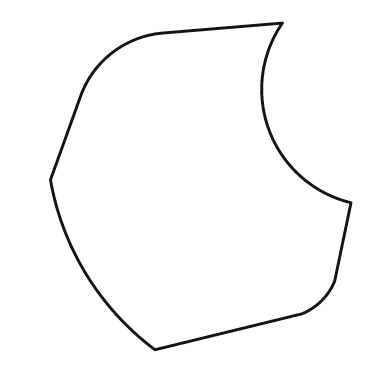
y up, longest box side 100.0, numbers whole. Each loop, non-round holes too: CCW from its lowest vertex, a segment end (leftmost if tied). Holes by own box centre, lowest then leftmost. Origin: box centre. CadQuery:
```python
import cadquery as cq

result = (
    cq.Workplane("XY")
    .moveTo(-14.0, -50.0)
    .lineTo(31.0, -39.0)
    .threePointArc((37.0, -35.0), (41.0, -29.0))
    .lineTo(46.0, -5.0)
    .threePointArc((21.0, 17.0), (25.0, 50.0))
    .lineTo(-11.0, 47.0)
    .threePointArc((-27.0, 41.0), (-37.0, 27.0))
    .lineTo(-46.0, 2.0)
    .threePointArc((-35.0, -27.0), (-14.0, -50.0))
    .close()
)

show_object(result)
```